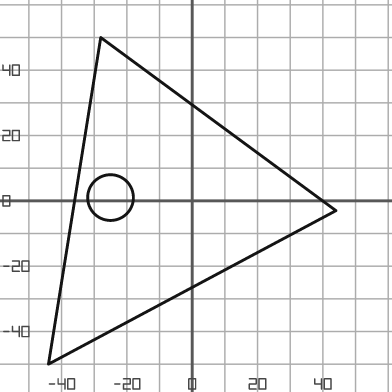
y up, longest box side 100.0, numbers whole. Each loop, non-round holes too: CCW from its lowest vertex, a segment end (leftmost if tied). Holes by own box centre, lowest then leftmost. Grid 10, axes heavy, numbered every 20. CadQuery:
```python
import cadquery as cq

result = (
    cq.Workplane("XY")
    .moveTo(-44.0, -50.0)
    .lineTo(44.0, -3.0)
    .lineTo(-28.0, 50.0)
    .close()
    .moveTo(-25.0, 1.0)
    .circle(7.0)
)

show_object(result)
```